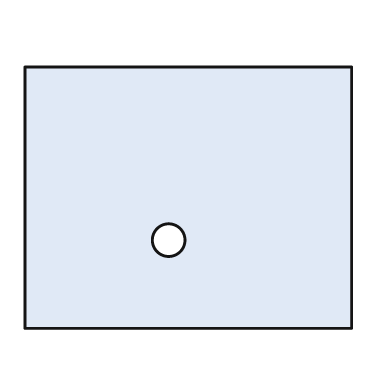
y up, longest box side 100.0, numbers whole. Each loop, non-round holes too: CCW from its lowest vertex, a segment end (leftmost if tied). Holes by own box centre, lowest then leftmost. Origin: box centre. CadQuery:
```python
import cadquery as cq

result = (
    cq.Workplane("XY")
    .moveTo(-50.0, -40.0)
    .lineTo(50.0, -40.0)
    .lineTo(50.0, 40.0)
    .lineTo(-50.0, 40.0)
    .close()
    .moveTo(-6.0, -13.0)
    .circle(5.0)
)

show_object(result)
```